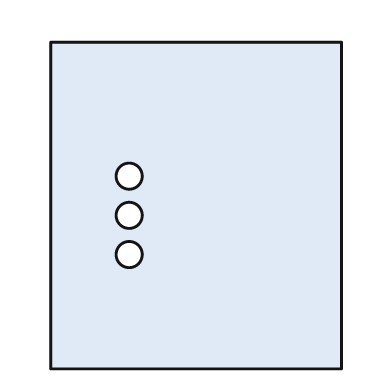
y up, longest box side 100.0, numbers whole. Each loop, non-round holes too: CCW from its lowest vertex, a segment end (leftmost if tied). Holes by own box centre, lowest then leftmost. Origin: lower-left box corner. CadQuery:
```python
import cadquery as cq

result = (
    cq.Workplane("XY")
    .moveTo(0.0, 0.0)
    .lineTo(89.0, 0.0)
    .lineTo(89.0, 100.0)
    .lineTo(0.0, 100.0)
    .close()
    .moveTo(24.0, 35.0)
    .circle(4.0)
    .moveTo(24.0, 47.0)
    .circle(4.0)
    .moveTo(24.0, 59.0)
    .circle(4.0)
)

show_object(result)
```